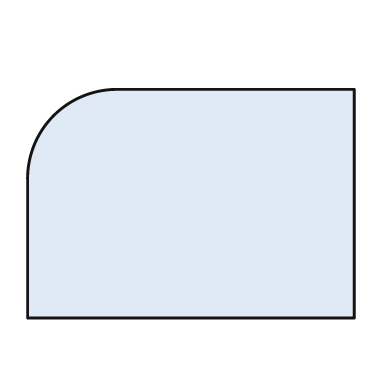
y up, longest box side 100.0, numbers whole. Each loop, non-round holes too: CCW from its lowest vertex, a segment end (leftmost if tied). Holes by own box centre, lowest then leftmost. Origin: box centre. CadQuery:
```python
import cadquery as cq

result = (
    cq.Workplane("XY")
    .moveTo(-50.0, -35.0)
    .lineTo(50.0, -35.0)
    .lineTo(50.0, 35.0)
    .lineTo(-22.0, 35.0)
    .threePointArc((-42.0, 27.0), (-50.0, 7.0))
    .close()
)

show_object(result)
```